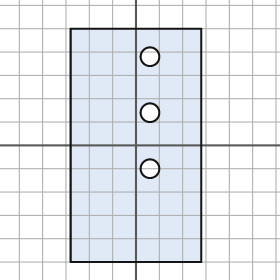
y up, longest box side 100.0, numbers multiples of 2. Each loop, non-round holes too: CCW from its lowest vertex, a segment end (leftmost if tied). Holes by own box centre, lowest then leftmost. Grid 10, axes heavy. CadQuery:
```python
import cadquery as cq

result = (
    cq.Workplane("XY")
    .moveTo(-28.0, -50.0)
    .lineTo(28.0, -50.0)
    .lineTo(28.0, 50.0)
    .lineTo(-28.0, 50.0)
    .close()
    .moveTo(6.0, -10.0)
    .circle(4.0)
    .moveTo(6.0, 14.0)
    .circle(4.0)
    .moveTo(6.0, 38.0)
    .circle(4.0)
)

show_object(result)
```